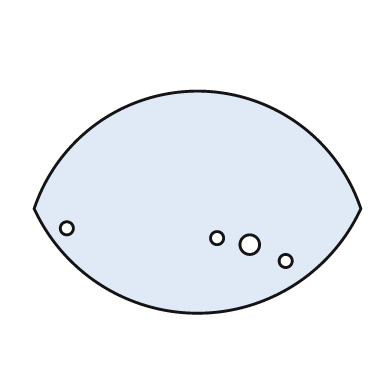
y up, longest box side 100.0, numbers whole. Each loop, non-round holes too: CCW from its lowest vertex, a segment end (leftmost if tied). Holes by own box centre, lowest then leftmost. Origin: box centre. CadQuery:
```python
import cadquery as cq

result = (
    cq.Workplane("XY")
    .moveTo(-50.0, -2.0)
    .threePointArc((0.0, -34.0), (50.0, -2.0))
    .threePointArc((0.0, 34.0), (-50.0, -2.0))
    .close()
    .moveTo(27.0, -18.0)
    .circle(2.0)
    .moveTo(16.0, -13.0)
    .circle(3.0)
    .moveTo(6.0, -11.0)
    .circle(2.0)
    .moveTo(-40.0, -8.0)
    .circle(2.0)
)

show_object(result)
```